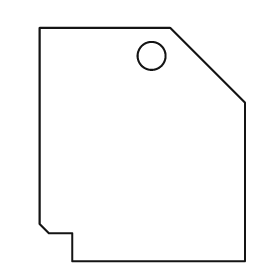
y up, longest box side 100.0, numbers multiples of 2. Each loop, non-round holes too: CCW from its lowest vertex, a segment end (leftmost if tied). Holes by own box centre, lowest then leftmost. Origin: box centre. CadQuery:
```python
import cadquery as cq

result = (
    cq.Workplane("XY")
    .moveTo(-30.0, -50.0)
    .lineTo(44.0, -50.0)
    .lineTo(44.0, 18.0)
    .lineTo(12.0, 50.0)
    .lineTo(-44.0, 50.0)
    .lineTo(-44.0, -34.0)
    .lineTo(-40.0, -38.0)
    .lineTo(-30.0, -38.0)
    .close()
    .moveTo(4.0, 38.0)
    .circle(6.0)
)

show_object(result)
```